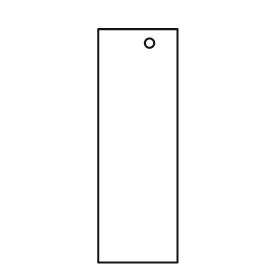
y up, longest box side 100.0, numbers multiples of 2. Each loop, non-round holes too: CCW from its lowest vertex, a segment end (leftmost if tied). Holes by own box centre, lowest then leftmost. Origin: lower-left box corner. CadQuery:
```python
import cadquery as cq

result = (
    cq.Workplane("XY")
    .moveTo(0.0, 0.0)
    .lineTo(34.0, 0.0)
    .lineTo(34.0, 100.0)
    .lineTo(0.0, 100.0)
    .close()
    .moveTo(22.0, 94.0)
    .circle(2.0)
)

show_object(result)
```